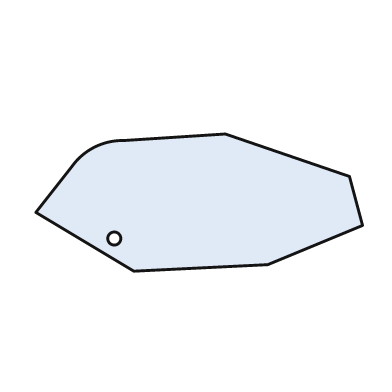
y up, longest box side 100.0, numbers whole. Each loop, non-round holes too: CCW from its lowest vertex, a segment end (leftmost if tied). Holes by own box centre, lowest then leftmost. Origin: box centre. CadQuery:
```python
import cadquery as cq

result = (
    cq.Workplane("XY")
    .moveTo(-20.0, -21.0)
    .lineTo(21.0, -19.0)
    .lineTo(50.0, -7.0)
    .lineTo(46.0, 8.0)
    .lineTo(8.0, 21.0)
    .lineTo(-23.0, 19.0)
    .threePointArc((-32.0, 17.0), (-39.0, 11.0))
    .lineTo(-50.0, -3.0)
    .close()
    .moveTo(-26.0, -11.0)
    .circle(2.0)
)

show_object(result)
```